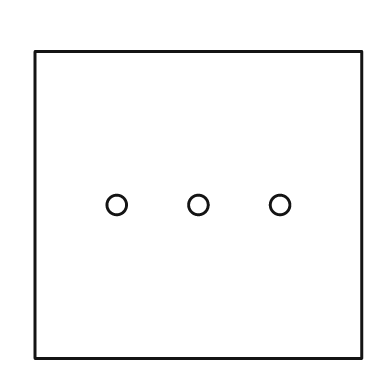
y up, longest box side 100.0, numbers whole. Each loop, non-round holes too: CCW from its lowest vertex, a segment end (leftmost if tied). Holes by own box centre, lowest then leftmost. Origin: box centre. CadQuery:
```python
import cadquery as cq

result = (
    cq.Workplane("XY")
    .moveTo(-50.0, -47.0)
    .lineTo(50.0, -47.0)
    .lineTo(50.0, 47.0)
    .lineTo(-50.0, 47.0)
    .close()
    .moveTo(-25.0, 0.0)
    .circle(3.0)
    .moveTo(0.0, 0.0)
    .circle(3.0)
    .moveTo(25.0, 0.0)
    .circle(3.0)
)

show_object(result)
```